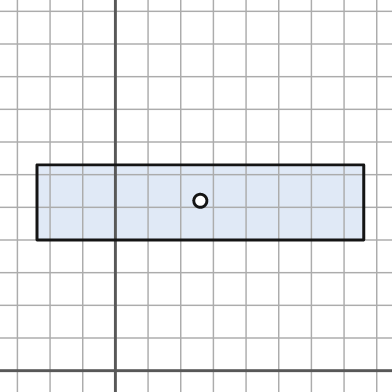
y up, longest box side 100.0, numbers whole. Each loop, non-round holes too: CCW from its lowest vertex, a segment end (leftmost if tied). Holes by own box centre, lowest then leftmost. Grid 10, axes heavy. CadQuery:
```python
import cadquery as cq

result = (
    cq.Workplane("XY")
    .moveTo(-24.0, 40.0)
    .lineTo(76.0, 40.0)
    .lineTo(76.0, 63.0)
    .lineTo(-24.0, 63.0)
    .close()
    .moveTo(26.0, 52.0)
    .circle(2.0)
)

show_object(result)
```